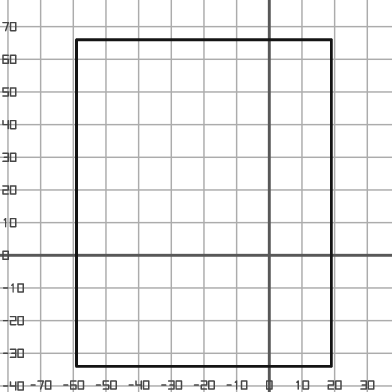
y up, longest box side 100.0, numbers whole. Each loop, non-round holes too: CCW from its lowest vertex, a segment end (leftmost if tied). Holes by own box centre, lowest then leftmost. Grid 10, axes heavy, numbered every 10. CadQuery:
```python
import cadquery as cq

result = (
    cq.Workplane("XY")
    .moveTo(-59.0, -34.0)
    .lineTo(19.0, -34.0)
    .lineTo(19.0, 66.0)
    .lineTo(-59.0, 66.0)
    .close()
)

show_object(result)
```